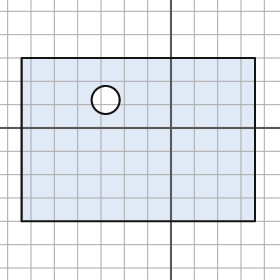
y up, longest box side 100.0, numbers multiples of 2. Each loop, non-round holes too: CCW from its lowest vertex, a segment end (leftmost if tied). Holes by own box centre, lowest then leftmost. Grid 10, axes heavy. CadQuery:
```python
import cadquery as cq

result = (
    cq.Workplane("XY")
    .moveTo(-64.0, -40.0)
    .lineTo(36.0, -40.0)
    .lineTo(36.0, 30.0)
    .lineTo(-64.0, 30.0)
    .close()
    .moveTo(-28.0, 12.0)
    .circle(6.0)
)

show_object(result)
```